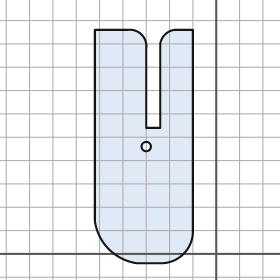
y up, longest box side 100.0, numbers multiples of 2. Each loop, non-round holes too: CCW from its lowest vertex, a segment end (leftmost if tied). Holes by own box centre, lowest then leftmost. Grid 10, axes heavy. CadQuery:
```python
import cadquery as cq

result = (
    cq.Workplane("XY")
    .moveTo(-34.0, -4.0)
    .lineTo(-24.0, -4.0)
    .threePointArc((-14.0, 0.0), (-10.0, 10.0))
    .lineTo(-10.0, 96.0)
    .lineTo(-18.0, 96.0)
    .threePointArc((-22.0, 94.0), (-24.0, 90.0))
    .lineTo(-24.0, 54.0)
    .lineTo(-30.0, 54.0)
    .lineTo(-30.0, 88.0)
    .threePointArc((-32.0, 94.0), (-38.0, 96.0))
    .lineTo(-52.0, 96.0)
    .lineTo(-52.0, 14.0)
    .threePointArc((-46.0, 2.0), (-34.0, -4.0))
    .close()
    .moveTo(-30.0, 46.0)
    .circle(2.0)
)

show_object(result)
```